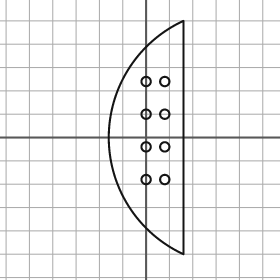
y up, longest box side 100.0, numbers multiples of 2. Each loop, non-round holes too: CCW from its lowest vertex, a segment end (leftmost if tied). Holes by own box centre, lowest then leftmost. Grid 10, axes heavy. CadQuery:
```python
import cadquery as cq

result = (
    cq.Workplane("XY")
    .moveTo(16.0, -50.0)
    .lineTo(16.0, 50.0)
    .threePointArc((-16.0, 0.0), (16.0, -50.0))
    .close()
    .moveTo(0.0, -18.0)
    .circle(2.0)
    .moveTo(8.0, -18.0)
    .circle(2.0)
    .moveTo(0.0, -4.0)
    .circle(2.0)
    .moveTo(8.0, -4.0)
    .circle(2.0)
    .moveTo(0.0, 10.0)
    .circle(2.0)
    .moveTo(8.0, 10.0)
    .circle(2.0)
    .moveTo(0.0, 24.0)
    .circle(2.0)
    .moveTo(8.0, 24.0)
    .circle(2.0)
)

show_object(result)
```